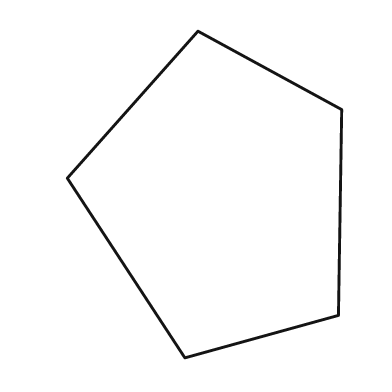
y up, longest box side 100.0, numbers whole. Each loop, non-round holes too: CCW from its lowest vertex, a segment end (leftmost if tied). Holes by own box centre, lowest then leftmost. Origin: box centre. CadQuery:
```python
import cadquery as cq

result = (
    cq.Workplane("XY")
    .moveTo(-6.0, -50.0)
    .lineTo(41.0, -37.0)
    .lineTo(42.0, 26.0)
    .lineTo(-2.0, 50.0)
    .lineTo(-42.0, 5.0)
    .close()
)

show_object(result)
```